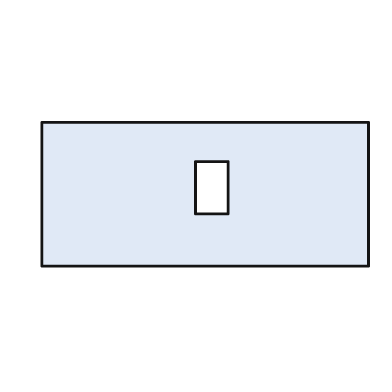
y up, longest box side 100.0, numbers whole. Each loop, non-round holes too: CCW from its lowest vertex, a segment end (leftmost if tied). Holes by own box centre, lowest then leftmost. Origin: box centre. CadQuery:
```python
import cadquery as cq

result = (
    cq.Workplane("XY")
    .moveTo(-50.0, -22.0)
    .lineTo(50.0, -22.0)
    .lineTo(50.0, 22.0)
    .lineTo(-50.0, 22.0)
    .close()
    .moveTo(-3.0, -6.0)
    .lineTo(7.0, -6.0)
    .lineTo(7.0, 10.0)
    .lineTo(-3.0, 10.0)
    .close()
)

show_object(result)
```